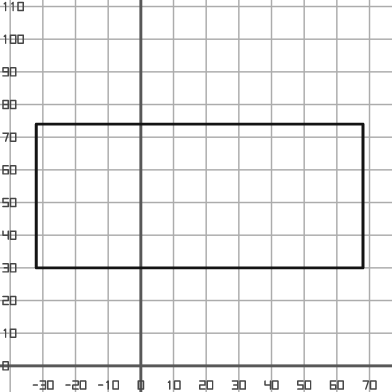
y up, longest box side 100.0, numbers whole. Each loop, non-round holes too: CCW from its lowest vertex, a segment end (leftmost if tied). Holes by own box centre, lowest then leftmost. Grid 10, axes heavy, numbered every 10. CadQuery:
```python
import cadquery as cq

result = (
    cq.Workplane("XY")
    .moveTo(-32.0, 30.0)
    .lineTo(68.0, 30.0)
    .lineTo(68.0, 74.0)
    .lineTo(-32.0, 74.0)
    .close()
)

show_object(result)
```